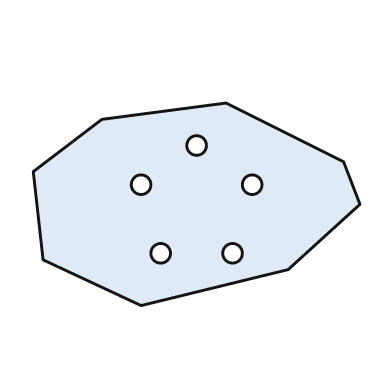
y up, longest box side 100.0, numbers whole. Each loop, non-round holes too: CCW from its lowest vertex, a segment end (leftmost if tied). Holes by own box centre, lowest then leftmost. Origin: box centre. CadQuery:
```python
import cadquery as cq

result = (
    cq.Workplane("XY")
    .moveTo(-17.0, -31.0)
    .lineTo(28.0, -20.0)
    .lineTo(50.0, 0.0)
    .lineTo(45.0, 13.0)
    .lineTo(9.0, 31.0)
    .lineTo(-29.0, 26.0)
    .lineTo(-50.0, 10.0)
    .lineTo(-47.0, -17.0)
    .close()
    .moveTo(-11.0, -15.0)
    .circle(3.0)
    .moveTo(11.0, -15.0)
    .circle(3.0)
    .moveTo(-17.0, 6.0)
    .circle(3.0)
    .moveTo(17.0, 6.0)
    .circle(3.0)
    .moveTo(0.0, 18.0)
    .circle(3.0)
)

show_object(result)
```